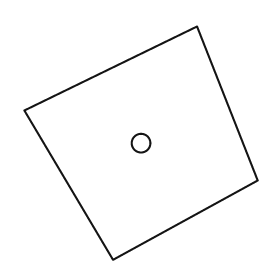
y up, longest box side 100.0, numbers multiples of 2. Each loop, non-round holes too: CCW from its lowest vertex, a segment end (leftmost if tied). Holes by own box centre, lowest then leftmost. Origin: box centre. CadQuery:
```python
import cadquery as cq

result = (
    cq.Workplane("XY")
    .moveTo(-12.0, -50.0)
    .lineTo(50.0, -16.0)
    .lineTo(24.0, 50.0)
    .lineTo(-50.0, 14.0)
    .close()
    .moveTo(0.0, 0.0)
    .circle(4.0)
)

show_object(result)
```